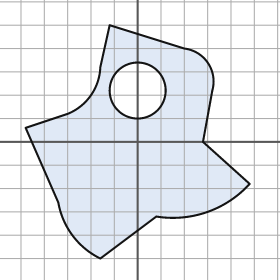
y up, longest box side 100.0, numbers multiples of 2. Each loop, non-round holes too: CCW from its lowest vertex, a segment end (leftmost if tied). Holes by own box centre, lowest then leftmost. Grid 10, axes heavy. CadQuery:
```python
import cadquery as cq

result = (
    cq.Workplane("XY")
    .moveTo(-16.0, -50.0)
    .lineTo(8.0, -32.0)
    .threePointArc((30.0, -30.0), (48.0, -18.0))
    .lineTo(28.0, 0.0)
    .lineTo(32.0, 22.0)
    .threePointArc((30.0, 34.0), (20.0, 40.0))
    .lineTo(-12.0, 50.0)
    .lineTo(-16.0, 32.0)
    .threePointArc((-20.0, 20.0), (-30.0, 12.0))
    .lineTo(-48.0, 6.0)
    .lineTo(-34.0, -26.0)
    .threePointArc((-28.0, -40.0), (-16.0, -50.0))
    .close()
    .moveTo(0.0, 22.0)
    .circle(12.0)
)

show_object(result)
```